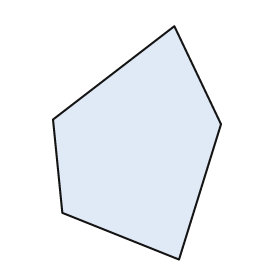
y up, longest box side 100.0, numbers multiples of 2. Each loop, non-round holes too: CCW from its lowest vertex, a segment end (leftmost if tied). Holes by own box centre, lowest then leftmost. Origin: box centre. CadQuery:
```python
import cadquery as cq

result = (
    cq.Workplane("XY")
    .moveTo(18.0, -50.0)
    .lineTo(36.0, 8.0)
    .lineTo(16.0, 50.0)
    .lineTo(-36.0, 10.0)
    .lineTo(-32.0, -30.0)
    .close()
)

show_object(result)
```